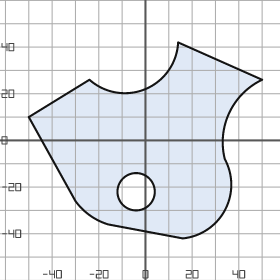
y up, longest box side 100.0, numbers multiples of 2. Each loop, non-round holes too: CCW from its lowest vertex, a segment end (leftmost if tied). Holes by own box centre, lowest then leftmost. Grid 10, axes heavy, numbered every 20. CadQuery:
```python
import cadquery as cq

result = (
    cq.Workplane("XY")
    .moveTo(16.0, -42.0)
    .threePointArc((34.0, -30.0), (34.0, -8.0))
    .threePointArc((36.0, 12.0), (50.0, 26.0))
    .lineTo(14.0, 42.0)
    .threePointArc((0.0, 22.0), (-24.0, 26.0))
    .lineTo(-50.0, 10.0)
    .lineTo(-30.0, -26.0)
    .threePointArc((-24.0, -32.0), (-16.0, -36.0))
    .close()
    .moveTo(-4.0, -22.0)
    .circle(8.0)
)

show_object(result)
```